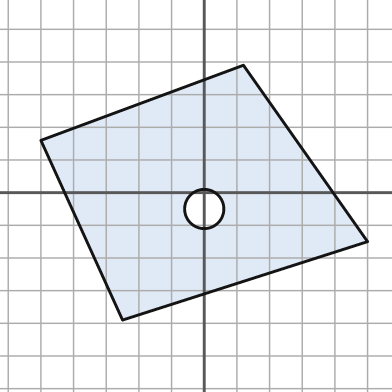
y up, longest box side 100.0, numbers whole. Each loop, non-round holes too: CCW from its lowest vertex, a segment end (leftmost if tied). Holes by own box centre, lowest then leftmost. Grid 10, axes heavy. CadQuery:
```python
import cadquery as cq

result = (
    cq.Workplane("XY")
    .moveTo(-25.0, -39.0)
    .lineTo(50.0, -15.0)
    .lineTo(12.0, 39.0)
    .lineTo(-50.0, 16.0)
    .close()
    .moveTo(0.0, -5.0)
    .circle(6.0)
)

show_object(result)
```